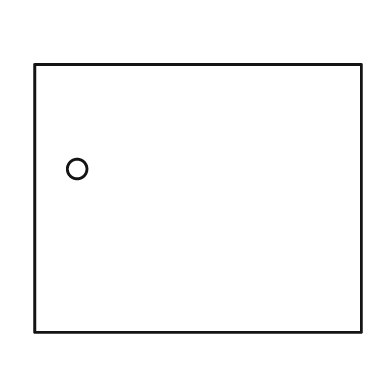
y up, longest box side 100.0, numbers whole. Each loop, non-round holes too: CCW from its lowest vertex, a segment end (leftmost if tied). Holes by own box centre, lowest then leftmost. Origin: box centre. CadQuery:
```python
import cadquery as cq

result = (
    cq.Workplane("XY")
    .moveTo(-50.0, -41.0)
    .lineTo(50.0, -41.0)
    .lineTo(50.0, 41.0)
    .lineTo(-50.0, 41.0)
    .close()
    .moveTo(-37.0, 9.0)
    .circle(3.0)
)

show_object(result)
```